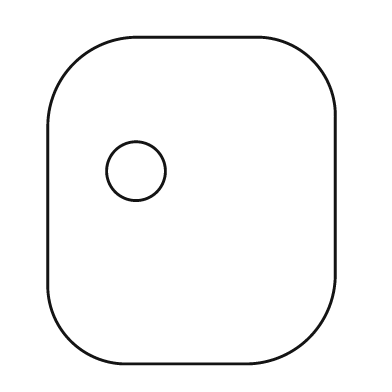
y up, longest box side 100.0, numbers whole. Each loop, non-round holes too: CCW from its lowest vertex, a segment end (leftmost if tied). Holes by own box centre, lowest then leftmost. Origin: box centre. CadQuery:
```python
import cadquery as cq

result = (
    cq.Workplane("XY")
    .moveTo(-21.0, -50.0)
    .lineTo(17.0, -50.0)
    .threePointArc((36.0, -42.0), (44.0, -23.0))
    .lineTo(44.0, 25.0)
    .threePointArc((37.0, 43.0), (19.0, 50.0))
    .lineTo(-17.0, 50.0)
    .threePointArc((-36.0, 42.0), (-44.0, 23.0))
    .lineTo(-44.0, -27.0)
    .threePointArc((-37.0, -43.0), (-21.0, -50.0))
    .close()
    .moveTo(-17.0, 9.0)
    .circle(9.0)
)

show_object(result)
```